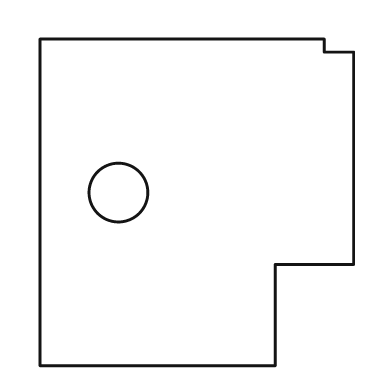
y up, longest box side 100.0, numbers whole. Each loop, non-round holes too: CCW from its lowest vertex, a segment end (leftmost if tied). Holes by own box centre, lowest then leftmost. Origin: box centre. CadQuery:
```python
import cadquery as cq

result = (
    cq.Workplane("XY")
    .moveTo(-48.0, -50.0)
    .lineTo(24.0, -50.0)
    .lineTo(24.0, -19.0)
    .lineTo(48.0, -19.0)
    .lineTo(48.0, 46.0)
    .lineTo(39.0, 46.0)
    .lineTo(39.0, 50.0)
    .lineTo(-48.0, 50.0)
    .close()
    .moveTo(-24.0, 3.0)
    .circle(9.0)
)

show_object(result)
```